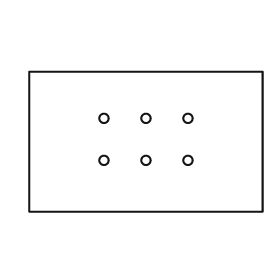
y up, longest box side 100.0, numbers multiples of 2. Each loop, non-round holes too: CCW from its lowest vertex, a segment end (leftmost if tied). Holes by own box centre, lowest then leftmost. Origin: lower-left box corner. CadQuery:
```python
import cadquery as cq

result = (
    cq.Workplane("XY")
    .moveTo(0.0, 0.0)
    .lineTo(100.0, 0.0)
    .lineTo(100.0, 60.0)
    .lineTo(0.0, 60.0)
    .close()
    .moveTo(32.0, 22.0)
    .circle(2.0)
    .moveTo(50.0, 22.0)
    .circle(2.0)
    .moveTo(68.0, 22.0)
    .circle(2.0)
    .moveTo(32.0, 40.0)
    .circle(2.0)
    .moveTo(50.0, 40.0)
    .circle(2.0)
    .moveTo(68.0, 40.0)
    .circle(2.0)
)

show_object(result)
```